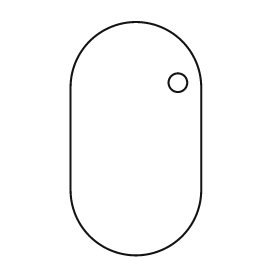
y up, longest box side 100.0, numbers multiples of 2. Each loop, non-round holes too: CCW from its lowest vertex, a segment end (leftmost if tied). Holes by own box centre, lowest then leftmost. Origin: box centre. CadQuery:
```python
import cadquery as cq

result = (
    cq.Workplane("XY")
    .moveTo(-28.0, -22.0)
    .threePointArc((0.0, -50.0), (28.0, -22.0))
    .lineTo(28.0, 22.0)
    .threePointArc((0.0, 50.0), (-28.0, 22.0))
    .close()
    .moveTo(18.0, 24.0)
    .circle(4.0)
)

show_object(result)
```